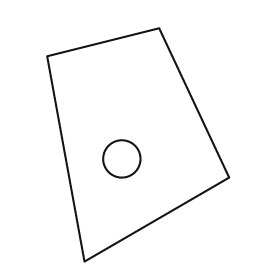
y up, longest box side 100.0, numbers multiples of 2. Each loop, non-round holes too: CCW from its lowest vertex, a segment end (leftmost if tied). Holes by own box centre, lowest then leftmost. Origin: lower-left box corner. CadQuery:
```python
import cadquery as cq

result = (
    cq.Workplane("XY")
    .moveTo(16.0, 0.0)
    .lineTo(78.0, 36.0)
    .lineTo(48.0, 100.0)
    .lineTo(0.0, 88.0)
    .close()
    .moveTo(32.0, 44.0)
    .circle(8.0)
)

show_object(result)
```